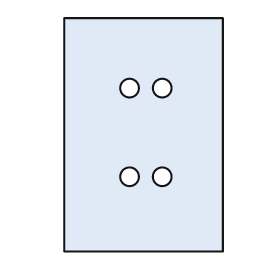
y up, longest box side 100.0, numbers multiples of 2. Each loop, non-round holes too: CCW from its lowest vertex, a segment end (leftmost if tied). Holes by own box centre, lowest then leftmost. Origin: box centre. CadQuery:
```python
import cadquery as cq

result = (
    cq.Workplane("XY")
    .moveTo(-34.0, -50.0)
    .lineTo(34.0, -50.0)
    .lineTo(34.0, 50.0)
    .lineTo(-34.0, 50.0)
    .close()
    .moveTo(-6.0, -18.0)
    .circle(4.0)
    .moveTo(8.0, -18.0)
    .circle(4.0)
    .moveTo(-6.0, 20.0)
    .circle(4.0)
    .moveTo(8.0, 20.0)
    .circle(4.0)
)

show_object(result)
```